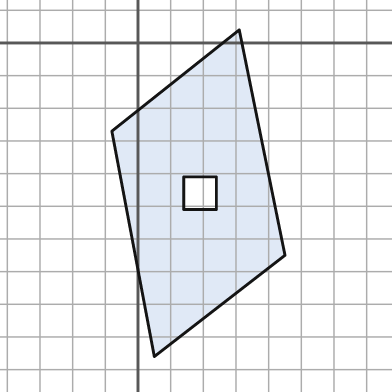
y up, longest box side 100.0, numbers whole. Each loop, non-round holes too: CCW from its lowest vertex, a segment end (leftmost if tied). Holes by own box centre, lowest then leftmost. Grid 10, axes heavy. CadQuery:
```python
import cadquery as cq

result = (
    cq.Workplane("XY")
    .moveTo(5.0, -96.0)
    .lineTo(45.0, -65.0)
    .lineTo(31.0, 4.0)
    .lineTo(-8.0, -27.0)
    .close()
    .moveTo(14.0, -51.0)
    .lineTo(24.0, -51.0)
    .lineTo(24.0, -41.0)
    .lineTo(14.0, -41.0)
    .close()
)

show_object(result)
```